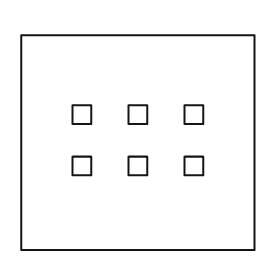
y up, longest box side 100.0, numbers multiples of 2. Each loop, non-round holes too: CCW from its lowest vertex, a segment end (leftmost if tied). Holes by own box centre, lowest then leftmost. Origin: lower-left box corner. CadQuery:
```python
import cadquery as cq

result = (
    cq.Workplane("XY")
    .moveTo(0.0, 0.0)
    .lineTo(100.0, 0.0)
    .lineTo(100.0, 92.0)
    .lineTo(0.0, 92.0)
    .close()
    .moveTo(22.0, 32.0)
    .lineTo(30.0, 32.0)
    .lineTo(30.0, 40.0)
    .lineTo(22.0, 40.0)
    .close()
    .moveTo(46.0, 32.0)
    .lineTo(54.0, 32.0)
    .lineTo(54.0, 40.0)
    .lineTo(46.0, 40.0)
    .close()
    .moveTo(70.0, 32.0)
    .lineTo(78.0, 32.0)
    .lineTo(78.0, 40.0)
    .lineTo(70.0, 40.0)
    .close()
    .moveTo(22.0, 54.0)
    .lineTo(30.0, 54.0)
    .lineTo(30.0, 62.0)
    .lineTo(22.0, 62.0)
    .close()
    .moveTo(46.0, 54.0)
    .lineTo(54.0, 54.0)
    .lineTo(54.0, 62.0)
    .lineTo(46.0, 62.0)
    .close()
    .moveTo(70.0, 54.0)
    .lineTo(78.0, 54.0)
    .lineTo(78.0, 62.0)
    .lineTo(70.0, 62.0)
    .close()
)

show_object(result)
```